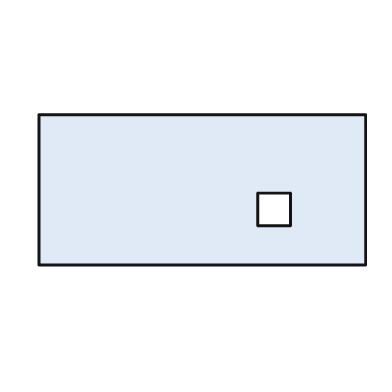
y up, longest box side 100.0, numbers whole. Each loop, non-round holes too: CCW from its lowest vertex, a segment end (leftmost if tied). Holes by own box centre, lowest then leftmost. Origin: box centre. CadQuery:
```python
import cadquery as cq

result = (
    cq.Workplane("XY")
    .moveTo(-50.0, -23.0)
    .lineTo(50.0, -23.0)
    .lineTo(50.0, 23.0)
    .lineTo(-50.0, 23.0)
    .close()
    .moveTo(17.0, -11.0)
    .lineTo(27.0, -11.0)
    .lineTo(27.0, -1.0)
    .lineTo(17.0, -1.0)
    .close()
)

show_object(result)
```